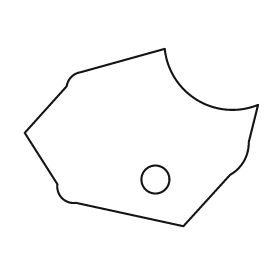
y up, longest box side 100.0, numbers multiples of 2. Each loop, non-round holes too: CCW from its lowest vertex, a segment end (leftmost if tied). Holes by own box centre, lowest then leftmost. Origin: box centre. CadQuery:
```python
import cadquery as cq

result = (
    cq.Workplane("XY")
    .moveTo(18.0, -38.0)
    .lineTo(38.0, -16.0)
    .threePointArc((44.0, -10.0), (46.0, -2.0))
    .lineTo(50.0, 14.0)
    .threePointArc((24.0, 16.0), (10.0, 38.0))
    .lineTo(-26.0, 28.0)
    .threePointArc((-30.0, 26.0), (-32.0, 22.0))
    .lineTo(-50.0, 2.0)
    .lineTo(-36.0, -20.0)
    .threePointArc((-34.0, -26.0), (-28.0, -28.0))
    .close()
    .moveTo(6.0, -18.0)
    .circle(6.0)
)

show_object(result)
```